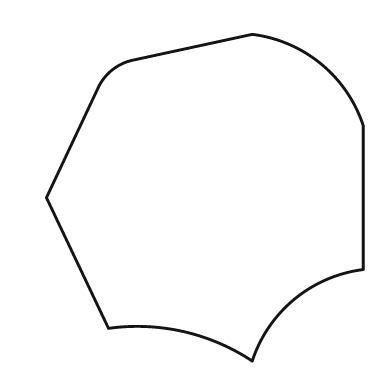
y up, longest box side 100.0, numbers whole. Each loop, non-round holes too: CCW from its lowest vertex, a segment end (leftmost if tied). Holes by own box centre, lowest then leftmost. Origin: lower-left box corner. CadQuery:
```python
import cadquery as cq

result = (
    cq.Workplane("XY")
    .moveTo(63.0, 0.0)
    .threePointArc((76.0, 19.0), (97.0, 28.0))
    .lineTo(97.0, 72.0)
    .threePointArc((84.0, 91.0), (63.0, 100.0))
    .lineTo(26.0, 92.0)
    .threePointArc((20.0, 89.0), (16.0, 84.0))
    .lineTo(0.0, 50.0)
    .lineTo(19.0, 10.0)
    .threePointArc((42.0, 9.0), (63.0, 0.0))
    .close()
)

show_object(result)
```